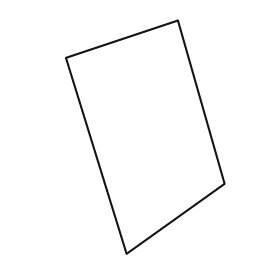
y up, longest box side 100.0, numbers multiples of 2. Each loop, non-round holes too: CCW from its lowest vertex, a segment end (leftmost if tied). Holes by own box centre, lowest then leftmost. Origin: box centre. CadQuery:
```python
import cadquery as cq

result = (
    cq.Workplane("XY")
    .moveTo(-8.0, -50.0)
    .lineTo(34.0, -20.0)
    .lineTo(14.0, 50.0)
    .lineTo(-34.0, 34.0)
    .close()
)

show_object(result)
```